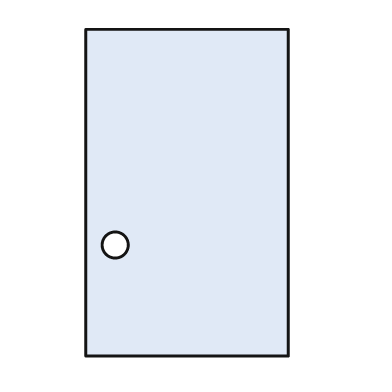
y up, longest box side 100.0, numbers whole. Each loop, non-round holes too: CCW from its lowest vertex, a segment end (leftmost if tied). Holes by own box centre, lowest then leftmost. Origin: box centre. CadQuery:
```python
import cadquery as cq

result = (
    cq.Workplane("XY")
    .moveTo(-31.0, -50.0)
    .lineTo(31.0, -50.0)
    .lineTo(31.0, 50.0)
    .lineTo(-31.0, 50.0)
    .close()
    .moveTo(-22.0, -16.0)
    .circle(4.0)
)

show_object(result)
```